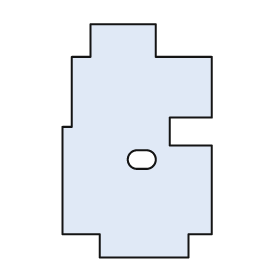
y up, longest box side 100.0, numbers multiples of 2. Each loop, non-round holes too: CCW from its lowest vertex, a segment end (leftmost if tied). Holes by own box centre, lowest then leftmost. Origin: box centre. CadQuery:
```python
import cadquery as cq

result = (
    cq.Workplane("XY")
    .moveTo(-16.0, -50.0)
    .lineTo(22.0, -50.0)
    .lineTo(22.0, -40.0)
    .lineTo(32.0, -40.0)
    .lineTo(32.0, -2.0)
    .lineTo(14.0, -2.0)
    .lineTo(14.0, 10.0)
    .lineTo(32.0, 10.0)
    .lineTo(32.0, 36.0)
    .lineTo(8.0, 36.0)
    .lineTo(8.0, 50.0)
    .lineTo(-20.0, 50.0)
    .lineTo(-20.0, 36.0)
    .lineTo(-28.0, 36.0)
    .lineTo(-28.0, 6.0)
    .lineTo(-32.0, 6.0)
    .lineTo(-32.0, -40.0)
    .lineTo(-16.0, -40.0)
    .close()
    .moveTo(0.0, -12.0)
    .lineTo(4.0, -12.0)
    .threePointArc((8.0, -8.0), (4.0, -4.0))
    .lineTo(0.0, -4.0)
    .threePointArc((-4.0, -8.0), (0.0, -12.0))
    .close()
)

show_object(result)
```